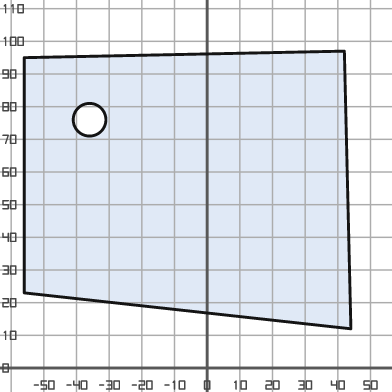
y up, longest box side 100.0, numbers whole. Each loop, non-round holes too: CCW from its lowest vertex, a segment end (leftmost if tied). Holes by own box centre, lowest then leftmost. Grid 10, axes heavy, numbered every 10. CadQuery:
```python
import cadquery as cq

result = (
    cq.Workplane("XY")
    .moveTo(44.0, 12.0)
    .lineTo(42.0, 97.0)
    .lineTo(-56.0, 95.0)
    .lineTo(-56.0, 23.0)
    .close()
    .moveTo(-36.0, 76.0)
    .circle(5.0)
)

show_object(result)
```